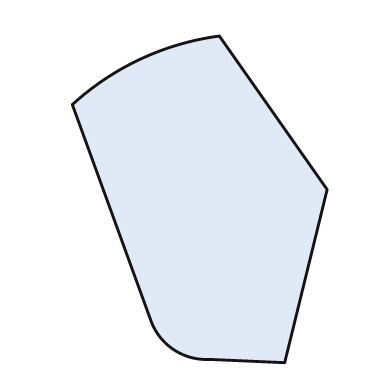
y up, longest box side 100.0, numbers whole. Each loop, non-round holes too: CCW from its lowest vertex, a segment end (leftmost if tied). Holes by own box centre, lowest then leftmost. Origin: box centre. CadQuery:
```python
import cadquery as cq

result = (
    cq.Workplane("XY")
    .moveTo(26.0, -50.0)
    .lineTo(39.0, 3.0)
    .lineTo(6.0, 50.0)
    .threePointArc((-18.0, 43.0), (-39.0, 29.0))
    .lineTo(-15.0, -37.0)
    .threePointArc((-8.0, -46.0), (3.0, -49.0))
    .close()
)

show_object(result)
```